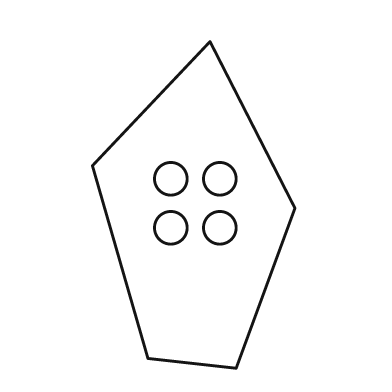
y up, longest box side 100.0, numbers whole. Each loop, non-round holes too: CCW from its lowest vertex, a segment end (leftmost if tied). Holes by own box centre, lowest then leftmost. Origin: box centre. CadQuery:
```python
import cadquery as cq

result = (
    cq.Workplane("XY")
    .moveTo(13.0, -50.0)
    .lineTo(31.0, -1.0)
    .lineTo(5.0, 50.0)
    .lineTo(-31.0, 12.0)
    .lineTo(-14.0, -47.0)
    .close()
    .moveTo(-7.0, -7.0)
    .circle(5.0)
    .moveTo(8.0, -7.0)
    .circle(5.0)
    .moveTo(-7.0, 8.0)
    .circle(5.0)
    .moveTo(8.0, 8.0)
    .circle(5.0)
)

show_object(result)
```